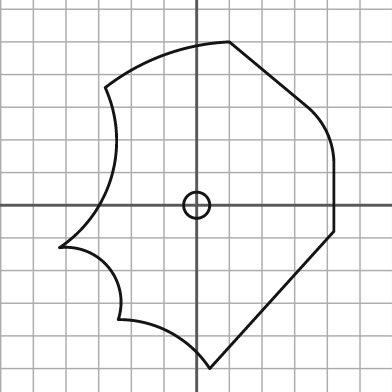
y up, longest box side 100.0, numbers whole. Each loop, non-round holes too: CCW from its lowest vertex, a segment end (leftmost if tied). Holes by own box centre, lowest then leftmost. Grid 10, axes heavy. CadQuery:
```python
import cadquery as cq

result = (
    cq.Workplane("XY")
    .moveTo(4.0, -50.0)
    .lineTo(42.0, -8.0)
    .lineTo(42.0, 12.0)
    .threePointArc((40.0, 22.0), (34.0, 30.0))
    .lineTo(10.0, 50.0)
    .threePointArc((-10.0, 46.0), (-28.0, 36.0))
    .threePointArc((-26.0, 9.0), (-42.0, -13.0))
    .threePointArc((-27.0, -19.0), (-24.0, -35.0))
    .threePointArc((-8.0, -39.0), (4.0, -50.0))
    .close()
    .moveTo(0.0, 0.0)
    .circle(4.0)
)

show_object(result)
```